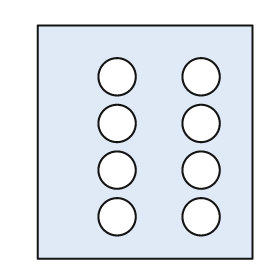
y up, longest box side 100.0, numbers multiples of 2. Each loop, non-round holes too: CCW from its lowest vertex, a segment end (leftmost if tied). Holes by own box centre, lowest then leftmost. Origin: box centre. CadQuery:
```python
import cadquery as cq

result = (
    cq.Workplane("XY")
    .moveTo(-46.0, -50.0)
    .lineTo(46.0, -50.0)
    .lineTo(46.0, 50.0)
    .lineTo(-46.0, 50.0)
    .close()
    .moveTo(-12.0, -32.0)
    .circle(8.0)
    .moveTo(24.0, -32.0)
    .circle(8.0)
    .moveTo(-12.0, -12.0)
    .circle(8.0)
    .moveTo(24.0, -12.0)
    .circle(8.0)
    .moveTo(-12.0, 8.0)
    .circle(8.0)
    .moveTo(24.0, 8.0)
    .circle(8.0)
    .moveTo(-12.0, 28.0)
    .circle(8.0)
    .moveTo(24.0, 28.0)
    .circle(8.0)
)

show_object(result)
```